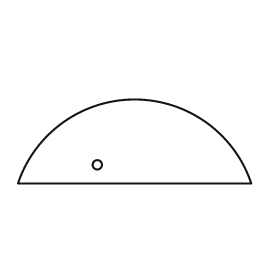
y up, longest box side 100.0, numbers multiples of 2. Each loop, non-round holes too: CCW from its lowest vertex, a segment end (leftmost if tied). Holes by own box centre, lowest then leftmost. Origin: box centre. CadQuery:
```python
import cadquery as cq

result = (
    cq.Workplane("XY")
    .moveTo(-50.0, -18.0)
    .lineTo(50.0, -18.0)
    .threePointArc((0.0, 18.0), (-50.0, -18.0))
    .close()
    .moveTo(-16.0, -10.0)
    .circle(2.0)
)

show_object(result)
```